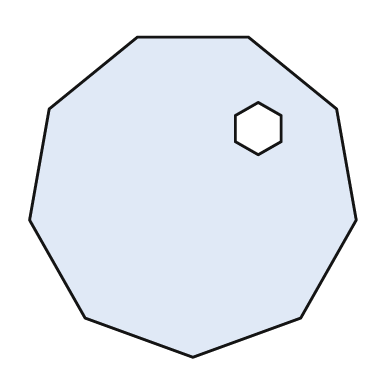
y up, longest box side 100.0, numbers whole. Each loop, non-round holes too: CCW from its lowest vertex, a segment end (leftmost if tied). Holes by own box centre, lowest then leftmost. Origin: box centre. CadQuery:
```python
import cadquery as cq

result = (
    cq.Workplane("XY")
    .moveTo(0.0, -49.0)
    .lineTo(33.0, -37.0)
    .lineTo(50.0, -7.0)
    .lineTo(44.0, 27.0)
    .lineTo(17.0, 49.0)
    .lineTo(-17.0, 49.0)
    .lineTo(-44.0, 27.0)
    .lineTo(-50.0, -7.0)
    .lineTo(-33.0, -37.0)
    .close()
    .moveTo(20.0, 13.0)
    .lineTo(27.0, 17.0)
    .lineTo(27.0, 25.0)
    .lineTo(20.0, 29.0)
    .lineTo(13.0, 25.0)
    .lineTo(13.0, 17.0)
    .close()
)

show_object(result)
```